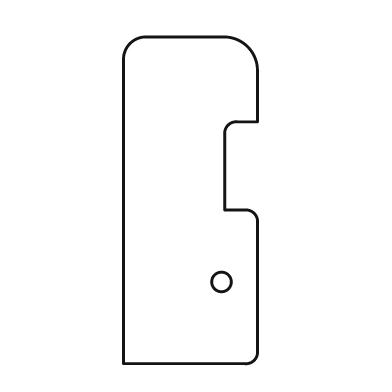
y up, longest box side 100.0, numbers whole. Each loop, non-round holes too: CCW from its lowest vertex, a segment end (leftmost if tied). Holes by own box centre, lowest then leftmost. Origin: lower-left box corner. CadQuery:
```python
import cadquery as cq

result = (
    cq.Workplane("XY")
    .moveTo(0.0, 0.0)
    .lineTo(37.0, 0.0)
    .threePointArc((40.0, 1.0), (41.0, 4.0))
    .lineTo(41.0, 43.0)
    .threePointArc((40.0, 46.0), (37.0, 47.0))
    .lineTo(31.0, 47.0)
    .lineTo(31.0, 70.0)
    .threePointArc((32.0, 73.0), (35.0, 74.0))
    .lineTo(41.0, 74.0)
    .lineTo(41.0, 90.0)
    .threePointArc((38.0, 97.0), (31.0, 100.0))
    .lineTo(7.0, 100.0)
    .threePointArc((2.0, 98.0), (0.0, 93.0))
    .close()
    .moveTo(30.0, 25.0)
    .circle(3.0)
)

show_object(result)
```